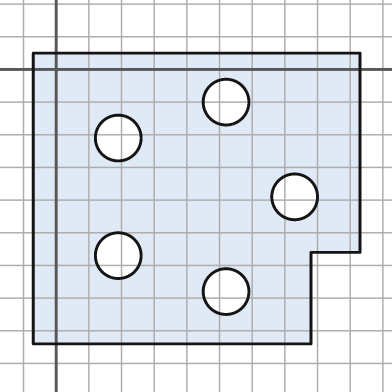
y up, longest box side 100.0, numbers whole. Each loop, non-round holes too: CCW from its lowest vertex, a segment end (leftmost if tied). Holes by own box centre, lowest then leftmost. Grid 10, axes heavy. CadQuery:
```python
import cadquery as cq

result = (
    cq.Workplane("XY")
    .moveTo(-7.0, -84.0)
    .lineTo(78.0, -84.0)
    .lineTo(78.0, -56.0)
    .lineTo(93.0, -56.0)
    .lineTo(93.0, 5.0)
    .lineTo(-7.0, 5.0)
    .close()
    .moveTo(52.0, -68.0)
    .circle(7.0)
    .moveTo(19.0, -57.0)
    .circle(7.0)
    .moveTo(73.0, -39.0)
    .circle(7.0)
    .moveTo(19.0, -21.0)
    .circle(7.0)
    .moveTo(52.0, -10.0)
    .circle(7.0)
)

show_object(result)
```